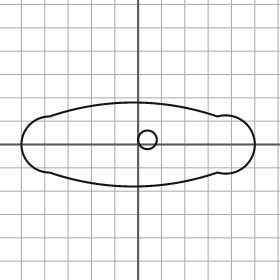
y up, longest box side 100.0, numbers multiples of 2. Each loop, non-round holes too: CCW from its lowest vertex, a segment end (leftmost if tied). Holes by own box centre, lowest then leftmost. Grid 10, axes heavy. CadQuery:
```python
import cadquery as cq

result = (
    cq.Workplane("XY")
    .moveTo(-38.0, -12.0)
    .threePointArc((-2.0, -18.0), (34.0, -12.0))
    .threePointArc((50.0, 0.0), (34.0, 12.0))
    .threePointArc((-2.0, 18.0), (-38.0, 12.0))
    .threePointArc((-50.0, 0.0), (-38.0, -12.0))
    .close()
    .moveTo(4.0, 2.0)
    .circle(4.0)
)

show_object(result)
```